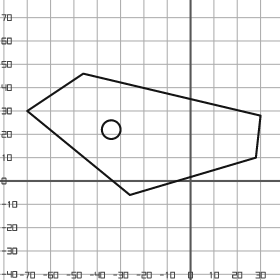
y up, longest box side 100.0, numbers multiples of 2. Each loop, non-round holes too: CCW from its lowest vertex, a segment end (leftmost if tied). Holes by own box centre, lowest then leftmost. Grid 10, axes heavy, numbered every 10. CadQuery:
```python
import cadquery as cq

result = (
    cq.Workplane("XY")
    .moveTo(-26.0, -6.0)
    .lineTo(28.0, 10.0)
    .lineTo(30.0, 28.0)
    .lineTo(-46.0, 46.0)
    .lineTo(-70.0, 30.0)
    .close()
    .moveTo(-34.0, 22.0)
    .circle(4.0)
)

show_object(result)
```